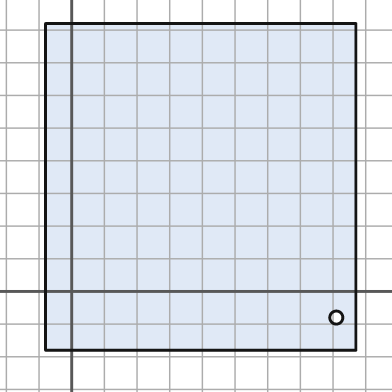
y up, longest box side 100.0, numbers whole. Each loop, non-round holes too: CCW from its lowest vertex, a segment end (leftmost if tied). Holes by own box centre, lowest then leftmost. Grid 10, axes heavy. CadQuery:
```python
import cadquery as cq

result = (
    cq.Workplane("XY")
    .moveTo(-8.0, -18.0)
    .lineTo(87.0, -18.0)
    .lineTo(87.0, 82.0)
    .lineTo(-8.0, 82.0)
    .close()
    .moveTo(81.0, -8.0)
    .circle(2.0)
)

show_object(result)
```